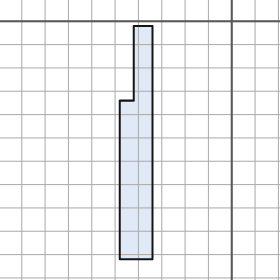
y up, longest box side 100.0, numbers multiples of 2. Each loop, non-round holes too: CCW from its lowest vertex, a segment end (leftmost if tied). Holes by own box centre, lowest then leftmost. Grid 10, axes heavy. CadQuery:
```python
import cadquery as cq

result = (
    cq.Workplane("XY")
    .moveTo(-48.0, -102.0)
    .lineTo(-34.0, -102.0)
    .lineTo(-34.0, -2.0)
    .lineTo(-42.0, -2.0)
    .lineTo(-42.0, -34.0)
    .lineTo(-48.0, -34.0)
    .close()
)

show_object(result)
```